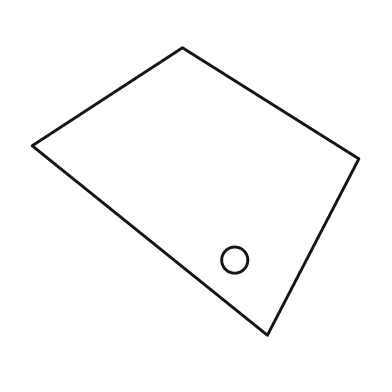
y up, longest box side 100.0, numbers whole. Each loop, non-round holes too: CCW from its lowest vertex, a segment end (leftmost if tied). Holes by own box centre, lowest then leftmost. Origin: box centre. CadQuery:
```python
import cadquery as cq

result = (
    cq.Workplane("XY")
    .moveTo(22.0, -44.0)
    .lineTo(50.0, 10.0)
    .lineTo(-4.0, 44.0)
    .lineTo(-50.0, 14.0)
    .close()
    .moveTo(12.0, -21.0)
    .circle(4.0)
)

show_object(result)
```